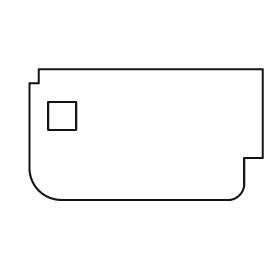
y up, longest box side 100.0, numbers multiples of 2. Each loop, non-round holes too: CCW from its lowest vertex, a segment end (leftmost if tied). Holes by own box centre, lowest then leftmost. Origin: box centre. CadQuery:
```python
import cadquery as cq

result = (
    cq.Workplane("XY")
    .moveTo(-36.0, -28.0)
    .lineTo(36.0, -28.0)
    .threePointArc((40.0, -26.0), (42.0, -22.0))
    .lineTo(42.0, -10.0)
    .lineTo(50.0, -10.0)
    .lineTo(50.0, 28.0)
    .lineTo(-46.0, 28.0)
    .lineTo(-46.0, 22.0)
    .lineTo(-50.0, 22.0)
    .lineTo(-50.0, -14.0)
    .threePointArc((-46.0, -24.0), (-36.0, -28.0))
    .close()
    .moveTo(-42.0, 2.0)
    .lineTo(-30.0, 2.0)
    .lineTo(-30.0, 14.0)
    .lineTo(-42.0, 14.0)
    .close()
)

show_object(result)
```